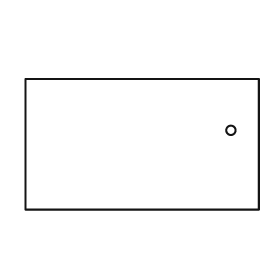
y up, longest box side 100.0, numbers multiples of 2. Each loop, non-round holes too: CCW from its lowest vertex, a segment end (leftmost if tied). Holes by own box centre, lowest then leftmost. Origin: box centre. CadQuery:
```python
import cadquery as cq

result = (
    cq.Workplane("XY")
    .moveTo(-50.0, -28.0)
    .lineTo(50.0, -28.0)
    .lineTo(50.0, 28.0)
    .lineTo(-50.0, 28.0)
    .close()
    .moveTo(38.0, 6.0)
    .circle(2.0)
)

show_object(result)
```